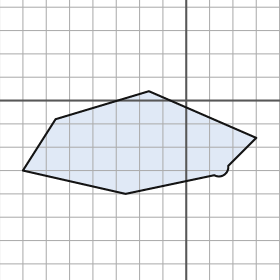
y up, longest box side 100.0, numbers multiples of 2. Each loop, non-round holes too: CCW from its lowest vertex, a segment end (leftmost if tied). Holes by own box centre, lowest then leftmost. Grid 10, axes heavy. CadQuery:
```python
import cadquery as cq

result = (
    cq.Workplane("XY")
    .moveTo(-26.0, -40.0)
    .lineTo(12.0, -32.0)
    .threePointArc((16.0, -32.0), (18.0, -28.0))
    .lineTo(30.0, -16.0)
    .lineTo(-16.0, 4.0)
    .lineTo(-56.0, -8.0)
    .lineTo(-70.0, -30.0)
    .close()
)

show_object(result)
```